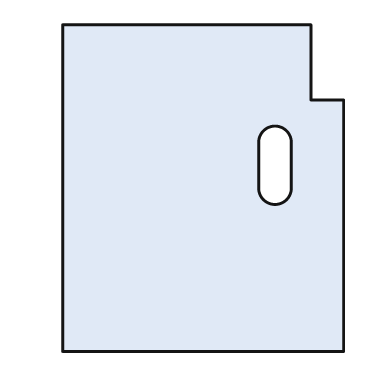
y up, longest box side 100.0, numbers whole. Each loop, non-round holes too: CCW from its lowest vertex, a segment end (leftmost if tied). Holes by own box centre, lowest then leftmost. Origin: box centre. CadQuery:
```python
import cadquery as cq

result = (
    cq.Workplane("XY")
    .moveTo(-43.0, -50.0)
    .lineTo(43.0, -50.0)
    .lineTo(43.0, 27.0)
    .lineTo(33.0, 27.0)
    .lineTo(33.0, 50.0)
    .lineTo(-43.0, 50.0)
    .close()
    .moveTo(17.0, 0.0)
    .threePointArc((22.0, -5.0), (27.0, 0.0))
    .lineTo(27.0, 14.0)
    .threePointArc((22.0, 19.0), (17.0, 14.0))
    .close()
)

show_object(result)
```